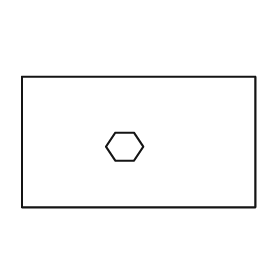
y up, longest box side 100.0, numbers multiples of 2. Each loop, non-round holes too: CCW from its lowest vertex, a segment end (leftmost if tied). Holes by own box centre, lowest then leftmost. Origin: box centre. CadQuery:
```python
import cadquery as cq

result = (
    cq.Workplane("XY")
    .moveTo(-50.0, -28.0)
    .lineTo(50.0, -28.0)
    .lineTo(50.0, 28.0)
    .lineTo(-50.0, 28.0)
    .close()
    .moveTo(-10.0, -8.0)
    .lineTo(-2.0, -8.0)
    .lineTo(2.0, -2.0)
    .lineTo(-2.0, 4.0)
    .lineTo(-10.0, 4.0)
    .lineTo(-14.0, -2.0)
    .close()
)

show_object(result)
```